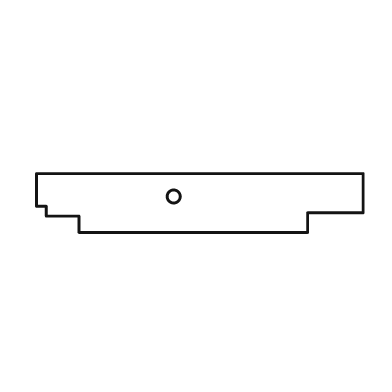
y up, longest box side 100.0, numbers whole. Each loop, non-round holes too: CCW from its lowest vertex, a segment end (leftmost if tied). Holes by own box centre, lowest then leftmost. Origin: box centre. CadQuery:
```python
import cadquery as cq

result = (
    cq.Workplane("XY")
    .moveTo(-37.0, -9.0)
    .lineTo(33.0, -9.0)
    .lineTo(33.0, -3.0)
    .lineTo(50.0, -3.0)
    .lineTo(50.0, 9.0)
    .lineTo(-50.0, 9.0)
    .lineTo(-50.0, -1.0)
    .lineTo(-47.0, -1.0)
    .lineTo(-47.0, -4.0)
    .lineTo(-37.0, -4.0)
    .close()
    .moveTo(-8.0, 2.0)
    .circle(2.0)
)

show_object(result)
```